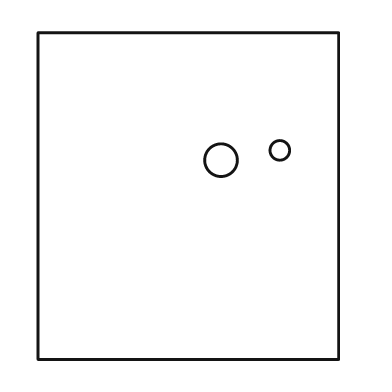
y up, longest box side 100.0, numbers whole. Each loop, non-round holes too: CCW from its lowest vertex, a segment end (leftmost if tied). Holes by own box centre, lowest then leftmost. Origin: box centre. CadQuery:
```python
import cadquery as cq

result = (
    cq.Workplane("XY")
    .moveTo(-46.0, -50.0)
    .lineTo(46.0, -50.0)
    .lineTo(46.0, 50.0)
    .lineTo(-46.0, 50.0)
    .close()
    .moveTo(10.0, 11.0)
    .circle(5.0)
    .moveTo(28.0, 14.0)
    .circle(3.0)
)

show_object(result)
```